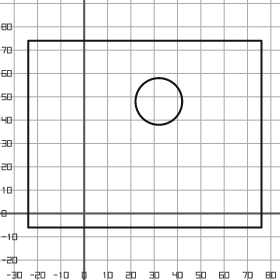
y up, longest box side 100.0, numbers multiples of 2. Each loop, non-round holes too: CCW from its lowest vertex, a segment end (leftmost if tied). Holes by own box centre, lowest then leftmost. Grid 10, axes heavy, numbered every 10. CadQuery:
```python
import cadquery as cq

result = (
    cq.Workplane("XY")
    .moveTo(-24.0, -6.0)
    .lineTo(76.0, -6.0)
    .lineTo(76.0, 74.0)
    .lineTo(-24.0, 74.0)
    .close()
    .moveTo(32.0, 48.0)
    .circle(10.0)
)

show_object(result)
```